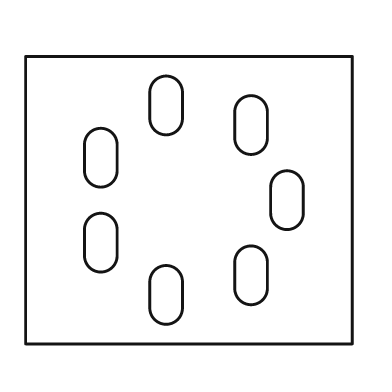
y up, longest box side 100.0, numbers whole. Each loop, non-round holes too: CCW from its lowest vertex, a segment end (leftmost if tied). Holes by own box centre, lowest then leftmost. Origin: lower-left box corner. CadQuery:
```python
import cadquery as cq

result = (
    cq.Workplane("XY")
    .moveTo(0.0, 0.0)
    .lineTo(100.0, 0.0)
    .lineTo(100.0, 88.0)
    .lineTo(0.0, 88.0)
    .close()
    .moveTo(38.0, 11.0)
    .threePointArc((43.0, 6.0), (48.0, 11.0))
    .lineTo(48.0, 19.0)
    .threePointArc((43.0, 24.0), (38.0, 19.0))
    .close()
    .moveTo(64.0, 17.0)
    .threePointArc((69.0, 12.0), (74.0, 17.0))
    .lineTo(74.0, 25.0)
    .threePointArc((69.0, 30.0), (64.0, 25.0))
    .close()
    .moveTo(18.0, 27.0)
    .threePointArc((23.0, 22.0), (28.0, 27.0))
    .lineTo(28.0, 35.0)
    .threePointArc((23.0, 40.0), (18.0, 35.0))
    .close()
    .moveTo(75.0, 40.0)
    .threePointArc((80.0, 35.0), (85.0, 40.0))
    .lineTo(85.0, 48.0)
    .threePointArc((80.0, 53.0), (75.0, 48.0))
    .close()
    .moveTo(18.0, 53.0)
    .threePointArc((23.0, 48.0), (28.0, 53.0))
    .lineTo(28.0, 61.0)
    .threePointArc((23.0, 66.0), (18.0, 61.0))
    .close()
    .moveTo(64.0, 63.0)
    .threePointArc((69.0, 58.0), (74.0, 63.0))
    .lineTo(74.0, 71.0)
    .threePointArc((69.0, 76.0), (64.0, 71.0))
    .close()
    .moveTo(38.0, 69.0)
    .threePointArc((43.0, 64.0), (48.0, 69.0))
    .lineTo(48.0, 77.0)
    .threePointArc((43.0, 82.0), (38.0, 77.0))
    .close()
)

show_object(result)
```